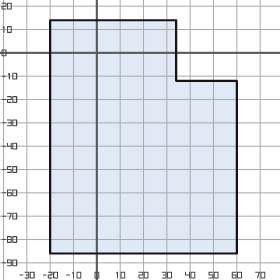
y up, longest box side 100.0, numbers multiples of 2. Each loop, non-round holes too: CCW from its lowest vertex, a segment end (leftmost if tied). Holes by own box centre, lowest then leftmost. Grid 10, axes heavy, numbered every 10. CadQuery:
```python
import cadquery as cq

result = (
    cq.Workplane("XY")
    .moveTo(-20.0, -86.0)
    .lineTo(60.0, -86.0)
    .lineTo(60.0, -12.0)
    .lineTo(34.0, -12.0)
    .lineTo(34.0, 14.0)
    .lineTo(-20.0, 14.0)
    .close()
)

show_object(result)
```